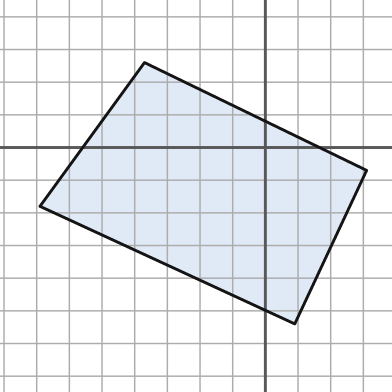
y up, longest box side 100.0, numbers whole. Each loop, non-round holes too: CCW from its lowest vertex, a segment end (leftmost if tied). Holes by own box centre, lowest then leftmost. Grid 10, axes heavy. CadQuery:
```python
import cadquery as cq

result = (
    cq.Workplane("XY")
    .moveTo(9.0, -54.0)
    .lineTo(31.0, -7.0)
    .lineTo(-37.0, 26.0)
    .lineTo(-69.0, -18.0)
    .close()
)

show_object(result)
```